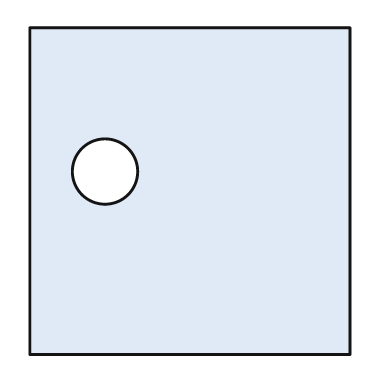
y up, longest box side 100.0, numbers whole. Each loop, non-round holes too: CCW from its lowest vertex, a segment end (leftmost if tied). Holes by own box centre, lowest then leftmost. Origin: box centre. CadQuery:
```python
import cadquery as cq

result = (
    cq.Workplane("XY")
    .moveTo(-49.0, -50.0)
    .lineTo(49.0, -50.0)
    .lineTo(49.0, 50.0)
    .lineTo(-49.0, 50.0)
    .close()
    .moveTo(-26.0, 6.0)
    .circle(10.0)
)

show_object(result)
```